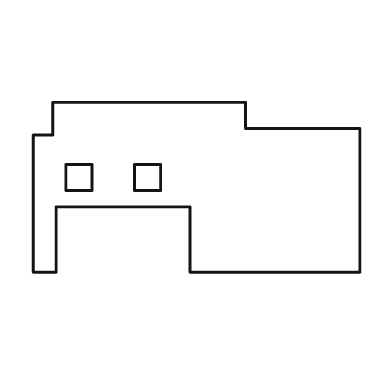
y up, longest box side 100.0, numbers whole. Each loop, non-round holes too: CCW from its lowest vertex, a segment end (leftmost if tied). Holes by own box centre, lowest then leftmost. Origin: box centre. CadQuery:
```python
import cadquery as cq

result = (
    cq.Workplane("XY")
    .moveTo(-50.0, -26.0)
    .lineTo(-43.0, -26.0)
    .lineTo(-43.0, -6.0)
    .lineTo(-2.0, -6.0)
    .lineTo(-2.0, -26.0)
    .lineTo(50.0, -26.0)
    .lineTo(50.0, 18.0)
    .lineTo(15.0, 18.0)
    .lineTo(15.0, 26.0)
    .lineTo(-44.0, 26.0)
    .lineTo(-44.0, 16.0)
    .lineTo(-50.0, 16.0)
    .close()
    .moveTo(-40.0, -1.0)
    .lineTo(-32.0, -1.0)
    .lineTo(-32.0, 7.0)
    .lineTo(-40.0, 7.0)
    .close()
    .moveTo(-19.0, -1.0)
    .lineTo(-11.0, -1.0)
    .lineTo(-11.0, 7.0)
    .lineTo(-19.0, 7.0)
    .close()
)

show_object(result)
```